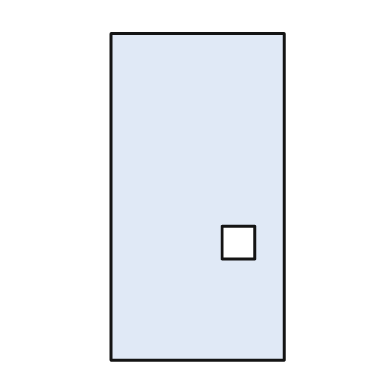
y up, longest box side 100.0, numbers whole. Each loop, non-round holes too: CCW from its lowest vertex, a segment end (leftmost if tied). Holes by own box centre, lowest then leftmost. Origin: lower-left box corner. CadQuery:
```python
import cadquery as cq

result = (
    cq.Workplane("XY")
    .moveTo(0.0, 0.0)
    .lineTo(53.0, 0.0)
    .lineTo(53.0, 100.0)
    .lineTo(0.0, 100.0)
    .close()
    .moveTo(34.0, 31.0)
    .lineTo(44.0, 31.0)
    .lineTo(44.0, 41.0)
    .lineTo(34.0, 41.0)
    .close()
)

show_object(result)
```